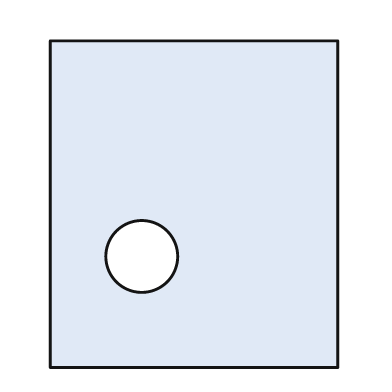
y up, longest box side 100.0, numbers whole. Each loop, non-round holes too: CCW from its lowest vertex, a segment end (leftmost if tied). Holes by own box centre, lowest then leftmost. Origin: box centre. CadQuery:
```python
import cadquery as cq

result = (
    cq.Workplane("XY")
    .moveTo(-44.0, -50.0)
    .lineTo(44.0, -50.0)
    .lineTo(44.0, 50.0)
    .lineTo(-44.0, 50.0)
    .close()
    .moveTo(-16.0, -16.0)
    .circle(11.0)
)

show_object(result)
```